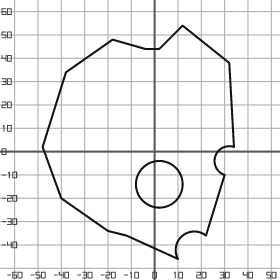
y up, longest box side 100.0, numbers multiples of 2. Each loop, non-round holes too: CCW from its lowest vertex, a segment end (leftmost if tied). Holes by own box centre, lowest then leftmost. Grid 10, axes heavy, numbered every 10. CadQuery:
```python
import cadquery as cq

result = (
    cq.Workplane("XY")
    .moveTo(10.0, -46.0)
    .threePointArc((12.0, -36.0), (22.0, -36.0))
    .lineTo(30.0, -10.0)
    .threePointArc((26.0, -2.0), (34.0, 2.0))
    .lineTo(32.0, 38.0)
    .lineTo(12.0, 54.0)
    .lineTo(2.0, 44.0)
    .lineTo(-4.0, 44.0)
    .lineTo(-18.0, 48.0)
    .lineTo(-38.0, 34.0)
    .lineTo(-48.0, 2.0)
    .lineTo(-40.0, -20.0)
    .lineTo(-20.0, -34.0)
    .lineTo(-12.0, -36.0)
    .close()
    .moveTo(2.0, -14.0)
    .circle(10.0)
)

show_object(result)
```